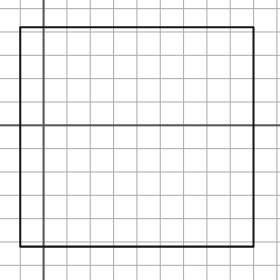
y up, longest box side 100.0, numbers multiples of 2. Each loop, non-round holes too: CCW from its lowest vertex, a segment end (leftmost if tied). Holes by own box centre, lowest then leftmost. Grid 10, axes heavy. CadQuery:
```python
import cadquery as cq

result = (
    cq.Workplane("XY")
    .moveTo(-10.0, -52.0)
    .lineTo(90.0, -52.0)
    .lineTo(90.0, 42.0)
    .lineTo(-10.0, 42.0)
    .close()
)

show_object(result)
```